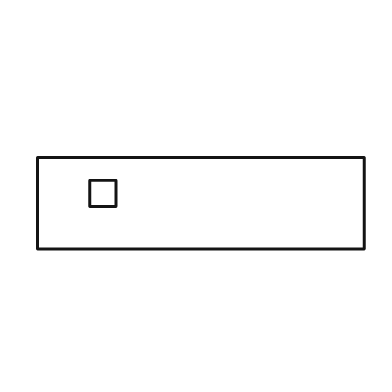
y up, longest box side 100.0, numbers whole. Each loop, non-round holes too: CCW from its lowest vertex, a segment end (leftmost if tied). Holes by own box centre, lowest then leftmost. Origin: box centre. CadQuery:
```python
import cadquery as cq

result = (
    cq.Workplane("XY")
    .moveTo(-50.0, -14.0)
    .lineTo(50.0, -14.0)
    .lineTo(50.0, 14.0)
    .lineTo(-50.0, 14.0)
    .close()
    .moveTo(-34.0, -1.0)
    .lineTo(-26.0, -1.0)
    .lineTo(-26.0, 7.0)
    .lineTo(-34.0, 7.0)
    .close()
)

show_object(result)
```